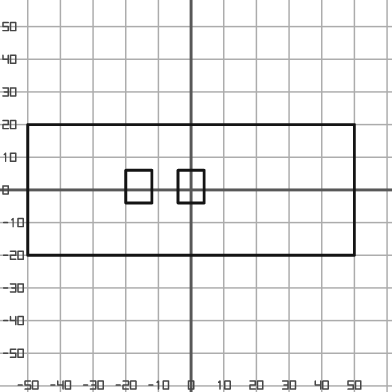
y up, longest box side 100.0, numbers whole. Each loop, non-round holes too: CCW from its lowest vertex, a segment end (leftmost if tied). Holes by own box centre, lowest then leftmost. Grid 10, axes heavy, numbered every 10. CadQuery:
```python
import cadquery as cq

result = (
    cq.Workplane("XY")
    .moveTo(-50.0, -20.0)
    .lineTo(50.0, -20.0)
    .lineTo(50.0, 20.0)
    .lineTo(-50.0, 20.0)
    .close()
    .moveTo(-20.0, -4.0)
    .lineTo(-12.0, -4.0)
    .lineTo(-12.0, 6.0)
    .lineTo(-20.0, 6.0)
    .close()
    .moveTo(-4.0, -4.0)
    .lineTo(4.0, -4.0)
    .lineTo(4.0, 6.0)
    .lineTo(-4.0, 6.0)
    .close()
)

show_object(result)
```